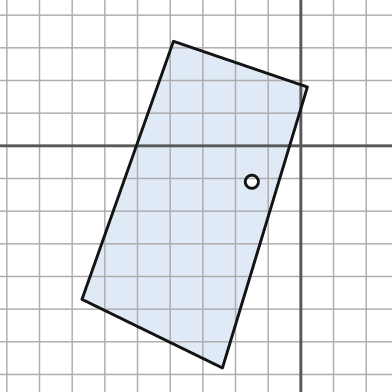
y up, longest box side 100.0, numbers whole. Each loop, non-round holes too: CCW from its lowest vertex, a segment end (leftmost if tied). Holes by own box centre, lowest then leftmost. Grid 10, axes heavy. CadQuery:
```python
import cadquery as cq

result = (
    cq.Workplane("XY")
    .moveTo(-24.0, -68.0)
    .lineTo(2.0, 18.0)
    .lineTo(-39.0, 32.0)
    .lineTo(-67.0, -47.0)
    .close()
    .moveTo(-15.0, -11.0)
    .circle(2.0)
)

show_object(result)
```